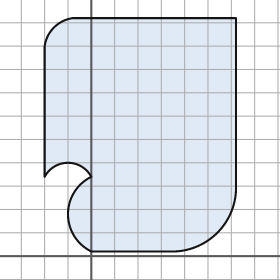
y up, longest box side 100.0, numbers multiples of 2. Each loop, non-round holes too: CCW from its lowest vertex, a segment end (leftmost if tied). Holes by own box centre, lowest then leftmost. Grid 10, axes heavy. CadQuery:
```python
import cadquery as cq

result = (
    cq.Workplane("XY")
    .moveTo(0.0, 2.0)
    .lineTo(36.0, 2.0)
    .threePointArc((54.0, 10.0), (62.0, 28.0))
    .lineTo(62.0, 102.0)
    .lineTo(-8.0, 102.0)
    .threePointArc((-16.0, 98.0), (-20.0, 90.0))
    .lineTo(-20.0, 34.0)
    .threePointArc((-10.0, 40.0), (0.0, 34.0))
    .threePointArc((-10.0, 18.0), (0.0, 2.0))
    .close()
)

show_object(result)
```